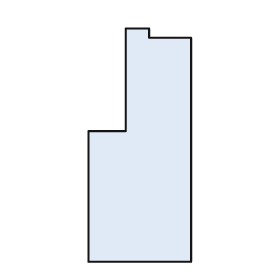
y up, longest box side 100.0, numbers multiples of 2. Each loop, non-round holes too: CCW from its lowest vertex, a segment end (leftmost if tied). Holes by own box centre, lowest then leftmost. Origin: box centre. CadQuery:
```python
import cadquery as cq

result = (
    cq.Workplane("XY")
    .moveTo(-22.0, -50.0)
    .lineTo(22.0, -50.0)
    .lineTo(22.0, 46.0)
    .lineTo(4.0, 46.0)
    .lineTo(4.0, 50.0)
    .lineTo(-6.0, 50.0)
    .lineTo(-6.0, 6.0)
    .lineTo(-22.0, 6.0)
    .close()
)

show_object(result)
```